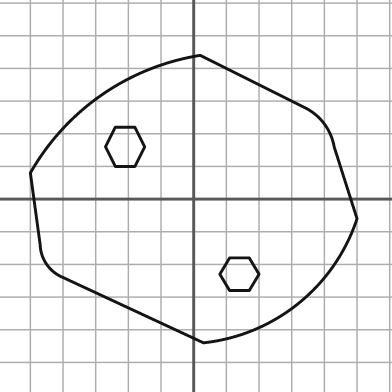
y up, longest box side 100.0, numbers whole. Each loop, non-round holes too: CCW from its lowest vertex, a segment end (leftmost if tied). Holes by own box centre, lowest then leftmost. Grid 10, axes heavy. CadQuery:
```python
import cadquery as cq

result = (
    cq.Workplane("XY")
    .moveTo(3.0, -44.0)
    .threePointArc((32.0, -32.0), (50.0, -6.0))
    .lineTo(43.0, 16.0)
    .threePointArc((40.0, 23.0), (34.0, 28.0))
    .lineTo(2.0, 44.0)
    .threePointArc((-28.0, 32.0), (-50.0, 8.0))
    .lineTo(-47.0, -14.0)
    .threePointArc((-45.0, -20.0), (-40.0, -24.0))
    .close()
    .moveTo(11.0, -28.0)
    .lineTo(17.0, -28.0)
    .lineTo(20.0, -23.0)
    .lineTo(17.0, -18.0)
    .lineTo(11.0, -18.0)
    .lineTo(8.0, -23.0)
    .close()
    .moveTo(-24.0, 10.0)
    .lineTo(-18.0, 10.0)
    .lineTo(-15.0, 16.0)
    .lineTo(-18.0, 22.0)
    .lineTo(-24.0, 22.0)
    .lineTo(-27.0, 16.0)
    .close()
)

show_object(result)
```